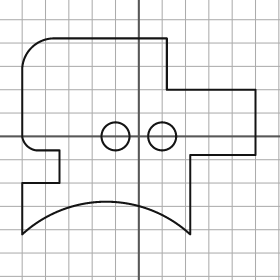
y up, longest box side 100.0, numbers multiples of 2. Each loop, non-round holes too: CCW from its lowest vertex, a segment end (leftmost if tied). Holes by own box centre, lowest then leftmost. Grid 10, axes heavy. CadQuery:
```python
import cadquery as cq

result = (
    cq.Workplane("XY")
    .moveTo(-50.0, -42.0)
    .threePointArc((-14.0, -28.0), (22.0, -42.0))
    .lineTo(22.0, -8.0)
    .lineTo(50.0, -8.0)
    .lineTo(50.0, 20.0)
    .lineTo(12.0, 20.0)
    .lineTo(12.0, 42.0)
    .lineTo(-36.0, 42.0)
    .threePointArc((-46.0, 38.0), (-50.0, 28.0))
    .lineTo(-50.0, 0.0)
    .threePointArc((-48.0, -4.0), (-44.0, -6.0))
    .lineTo(-34.0, -6.0)
    .lineTo(-34.0, -20.0)
    .lineTo(-50.0, -20.0)
    .close()
    .moveTo(-10.0, 0.0)
    .circle(6.0)
    .moveTo(10.0, 0.0)
    .circle(6.0)
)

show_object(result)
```